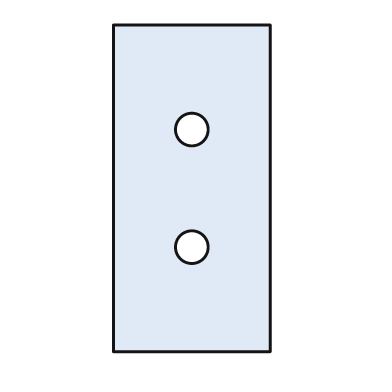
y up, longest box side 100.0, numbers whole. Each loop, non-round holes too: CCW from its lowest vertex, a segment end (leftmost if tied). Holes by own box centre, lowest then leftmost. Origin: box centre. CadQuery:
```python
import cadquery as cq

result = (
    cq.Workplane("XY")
    .moveTo(-24.0, -50.0)
    .lineTo(24.0, -50.0)
    .lineTo(24.0, 50.0)
    .lineTo(-24.0, 50.0)
    .close()
    .moveTo(0.0, -18.0)
    .circle(5.0)
    .moveTo(0.0, 18.0)
    .circle(5.0)
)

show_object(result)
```